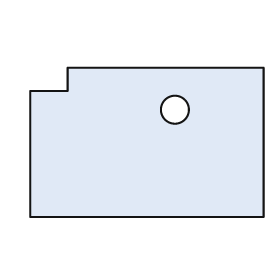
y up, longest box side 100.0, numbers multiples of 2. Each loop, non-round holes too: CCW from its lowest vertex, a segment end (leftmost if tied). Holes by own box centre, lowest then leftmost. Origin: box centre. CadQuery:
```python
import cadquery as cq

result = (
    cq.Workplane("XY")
    .moveTo(-50.0, -32.0)
    .lineTo(50.0, -32.0)
    .lineTo(50.0, 32.0)
    .lineTo(-34.0, 32.0)
    .lineTo(-34.0, 22.0)
    .lineTo(-50.0, 22.0)
    .close()
    .moveTo(12.0, 14.0)
    .circle(6.0)
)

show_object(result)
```